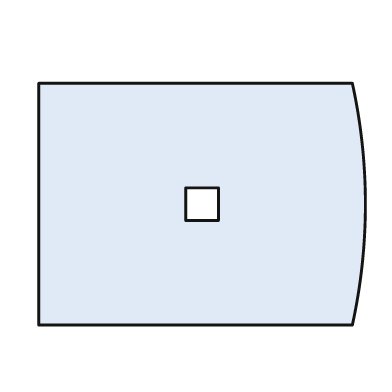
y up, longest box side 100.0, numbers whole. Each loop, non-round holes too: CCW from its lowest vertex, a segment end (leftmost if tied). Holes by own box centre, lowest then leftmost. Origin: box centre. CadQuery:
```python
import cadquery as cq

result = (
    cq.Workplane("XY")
    .moveTo(-50.0, -37.0)
    .lineTo(46.0, -37.0)
    .threePointArc((50.0, 0.0), (46.0, 37.0))
    .lineTo(-50.0, 37.0)
    .close()
    .moveTo(-5.0, -5.0)
    .lineTo(5.0, -5.0)
    .lineTo(5.0, 5.0)
    .lineTo(-5.0, 5.0)
    .close()
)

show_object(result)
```